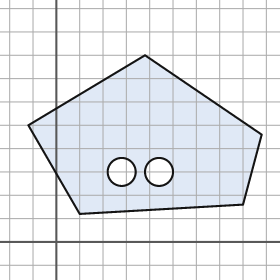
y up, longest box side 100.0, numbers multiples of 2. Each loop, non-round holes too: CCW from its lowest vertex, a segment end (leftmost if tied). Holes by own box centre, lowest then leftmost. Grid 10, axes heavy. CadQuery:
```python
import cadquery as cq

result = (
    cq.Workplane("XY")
    .moveTo(10.0, 12.0)
    .lineTo(80.0, 16.0)
    .lineTo(88.0, 46.0)
    .lineTo(38.0, 80.0)
    .lineTo(-12.0, 50.0)
    .close()
    .moveTo(28.0, 30.0)
    .circle(6.0)
    .moveTo(44.0, 30.0)
    .circle(6.0)
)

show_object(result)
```